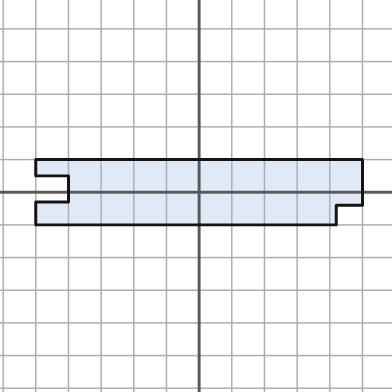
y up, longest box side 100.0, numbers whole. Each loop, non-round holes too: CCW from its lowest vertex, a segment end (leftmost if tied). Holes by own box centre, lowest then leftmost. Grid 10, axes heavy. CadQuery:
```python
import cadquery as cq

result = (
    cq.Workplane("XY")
    .moveTo(-50.0, -10.0)
    .lineTo(42.0, -10.0)
    .lineTo(42.0, -4.0)
    .lineTo(50.0, -4.0)
    .lineTo(50.0, 10.0)
    .lineTo(-50.0, 10.0)
    .lineTo(-50.0, 5.0)
    .lineTo(-40.0, 5.0)
    .lineTo(-40.0, -3.0)
    .lineTo(-50.0, -3.0)
    .close()
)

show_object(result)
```